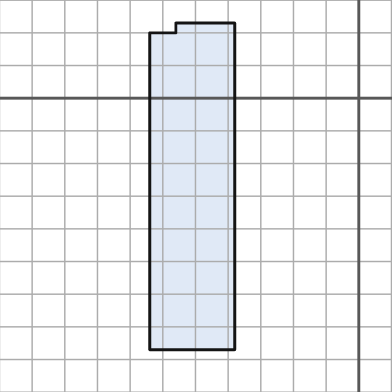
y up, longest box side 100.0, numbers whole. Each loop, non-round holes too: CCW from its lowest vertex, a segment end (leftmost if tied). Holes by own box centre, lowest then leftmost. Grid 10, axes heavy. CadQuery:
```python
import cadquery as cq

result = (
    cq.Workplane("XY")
    .moveTo(-64.0, -77.0)
    .lineTo(-38.0, -77.0)
    .lineTo(-38.0, 23.0)
    .lineTo(-56.0, 23.0)
    .lineTo(-56.0, 20.0)
    .lineTo(-64.0, 20.0)
    .close()
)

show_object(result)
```